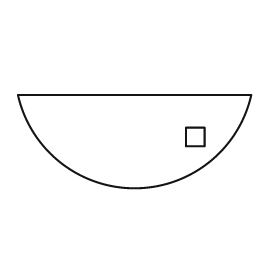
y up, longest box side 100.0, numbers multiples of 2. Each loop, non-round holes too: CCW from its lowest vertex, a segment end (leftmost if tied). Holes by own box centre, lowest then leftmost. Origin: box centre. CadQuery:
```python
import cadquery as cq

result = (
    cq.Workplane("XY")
    .moveTo(-50.0, 20.0)
    .threePointArc((0.0, -20.0), (50.0, 20.0))
    .close()
    .moveTo(22.0, -2.0)
    .lineTo(30.0, -2.0)
    .lineTo(30.0, 6.0)
    .lineTo(22.0, 6.0)
    .close()
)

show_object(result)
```